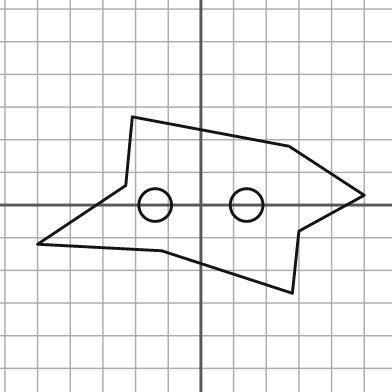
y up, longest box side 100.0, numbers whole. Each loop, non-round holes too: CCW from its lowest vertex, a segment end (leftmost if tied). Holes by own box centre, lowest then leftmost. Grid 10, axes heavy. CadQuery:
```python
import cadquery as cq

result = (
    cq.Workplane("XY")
    .moveTo(28.0, -27.0)
    .lineTo(30.0, -8.0)
    .lineTo(50.0, 3.0)
    .lineTo(27.0, 18.0)
    .lineTo(-21.0, 27.0)
    .lineTo(-23.0, 6.0)
    .lineTo(-50.0, -12.0)
    .lineTo(-12.0, -14.0)
    .close()
    .moveTo(-14.0, 0.0)
    .circle(5.0)
    .moveTo(14.0, 0.0)
    .circle(5.0)
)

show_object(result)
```